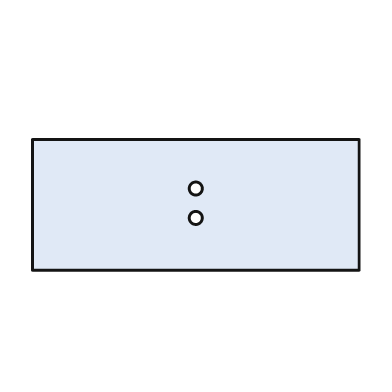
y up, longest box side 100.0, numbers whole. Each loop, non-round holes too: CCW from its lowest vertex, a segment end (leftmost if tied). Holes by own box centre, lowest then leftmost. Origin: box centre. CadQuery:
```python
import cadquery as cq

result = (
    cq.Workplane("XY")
    .moveTo(-50.0, -20.0)
    .lineTo(50.0, -20.0)
    .lineTo(50.0, 20.0)
    .lineTo(-50.0, 20.0)
    .close()
    .moveTo(0.0, -4.0)
    .circle(2.0)
    .moveTo(0.0, 5.0)
    .circle(2.0)
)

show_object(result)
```